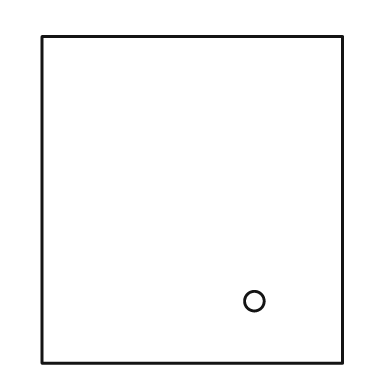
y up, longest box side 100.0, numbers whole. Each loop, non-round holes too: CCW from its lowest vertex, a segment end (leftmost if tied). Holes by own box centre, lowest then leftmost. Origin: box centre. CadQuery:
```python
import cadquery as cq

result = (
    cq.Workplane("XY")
    .moveTo(-46.0, -50.0)
    .lineTo(46.0, -50.0)
    .lineTo(46.0, 50.0)
    .lineTo(-46.0, 50.0)
    .close()
    .moveTo(19.0, -31.0)
    .circle(3.0)
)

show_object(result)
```